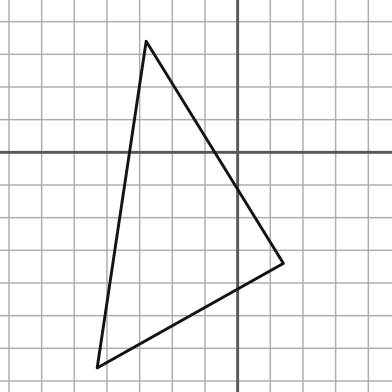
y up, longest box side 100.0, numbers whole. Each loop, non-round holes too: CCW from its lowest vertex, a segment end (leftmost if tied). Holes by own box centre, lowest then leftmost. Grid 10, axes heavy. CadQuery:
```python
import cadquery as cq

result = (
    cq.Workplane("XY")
    .moveTo(-43.0, -66.0)
    .lineTo(14.0, -34.0)
    .lineTo(-28.0, 34.0)
    .close()
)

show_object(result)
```